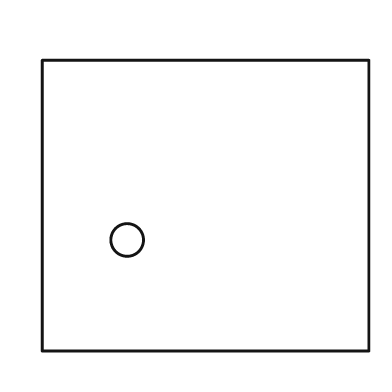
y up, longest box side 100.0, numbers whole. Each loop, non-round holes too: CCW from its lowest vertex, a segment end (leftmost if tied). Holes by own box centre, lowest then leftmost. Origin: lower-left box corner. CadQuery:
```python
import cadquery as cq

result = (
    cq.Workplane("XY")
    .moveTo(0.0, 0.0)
    .lineTo(100.0, 0.0)
    .lineTo(100.0, 89.0)
    .lineTo(0.0, 89.0)
    .close()
    .moveTo(26.0, 34.0)
    .circle(5.0)
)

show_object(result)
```